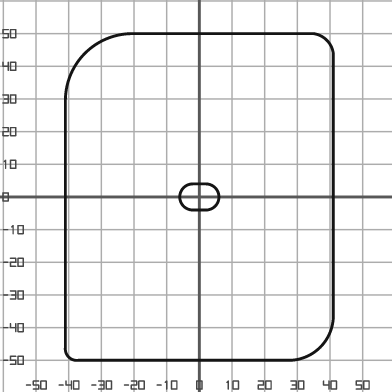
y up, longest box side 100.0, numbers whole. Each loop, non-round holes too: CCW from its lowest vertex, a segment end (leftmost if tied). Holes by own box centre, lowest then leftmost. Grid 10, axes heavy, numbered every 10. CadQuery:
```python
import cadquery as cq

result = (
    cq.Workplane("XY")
    .moveTo(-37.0, -50.0)
    .lineTo(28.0, -50.0)
    .threePointArc((37.0, -46.0), (41.0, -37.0))
    .lineTo(41.0, 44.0)
    .threePointArc((39.0, 48.0), (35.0, 50.0))
    .lineTo(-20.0, 50.0)
    .threePointArc((-35.0, 44.0), (-41.0, 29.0))
    .lineTo(-41.0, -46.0)
    .threePointArc((-40.0, -49.0), (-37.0, -50.0))
    .close()
    .moveTo(-2.0, -4.0)
    .lineTo(2.0, -4.0)
    .threePointArc((6.0, 0.0), (2.0, 4.0))
    .lineTo(-2.0, 4.0)
    .threePointArc((-6.0, 0.0), (-2.0, -4.0))
    .close()
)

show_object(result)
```